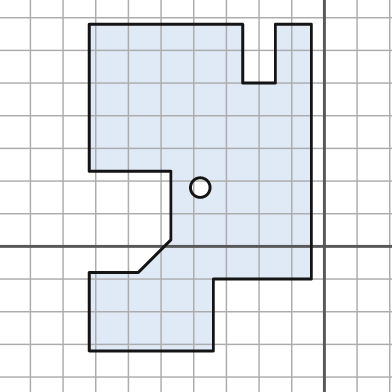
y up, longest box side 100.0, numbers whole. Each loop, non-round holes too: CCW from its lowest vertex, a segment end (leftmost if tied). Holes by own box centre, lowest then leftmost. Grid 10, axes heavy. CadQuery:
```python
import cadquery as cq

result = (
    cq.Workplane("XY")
    .moveTo(-72.0, -32.0)
    .lineTo(-34.0, -32.0)
    .lineTo(-34.0, -10.0)
    .lineTo(-4.0, -10.0)
    .lineTo(-4.0, 68.0)
    .lineTo(-15.0, 68.0)
    .lineTo(-15.0, 50.0)
    .lineTo(-25.0, 50.0)
    .lineTo(-25.0, 68.0)
    .lineTo(-72.0, 68.0)
    .lineTo(-72.0, 23.0)
    .lineTo(-47.0, 23.0)
    .lineTo(-47.0, 2.0)
    .lineTo(-57.0, -8.0)
    .lineTo(-72.0, -8.0)
    .close()
    .moveTo(-38.0, 18.0)
    .circle(3.0)
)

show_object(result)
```